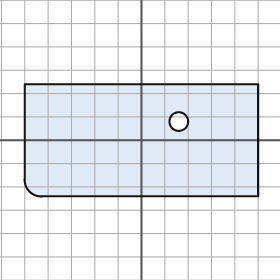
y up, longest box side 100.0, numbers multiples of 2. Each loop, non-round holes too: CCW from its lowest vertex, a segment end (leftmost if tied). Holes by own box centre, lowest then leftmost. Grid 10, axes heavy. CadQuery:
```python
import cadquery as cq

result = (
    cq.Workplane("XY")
    .moveTo(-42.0, -24.0)
    .lineTo(50.0, -24.0)
    .lineTo(50.0, 24.0)
    .lineTo(-50.0, 24.0)
    .lineTo(-50.0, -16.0)
    .threePointArc((-48.0, -22.0), (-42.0, -24.0))
    .close()
    .moveTo(16.0, 8.0)
    .circle(4.0)
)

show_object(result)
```